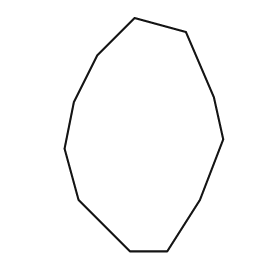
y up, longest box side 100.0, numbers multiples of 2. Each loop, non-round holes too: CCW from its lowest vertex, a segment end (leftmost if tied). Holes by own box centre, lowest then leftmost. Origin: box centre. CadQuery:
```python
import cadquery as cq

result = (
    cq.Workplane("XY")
    .moveTo(-6.0, -50.0)
    .lineTo(10.0, -50.0)
    .lineTo(24.0, -28.0)
    .lineTo(34.0, -2.0)
    .lineTo(30.0, 16.0)
    .lineTo(18.0, 44.0)
    .lineTo(-4.0, 50.0)
    .lineTo(-20.0, 34.0)
    .lineTo(-30.0, 14.0)
    .lineTo(-34.0, -6.0)
    .lineTo(-28.0, -28.0)
    .close()
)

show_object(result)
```